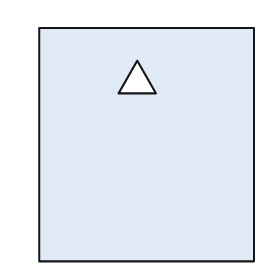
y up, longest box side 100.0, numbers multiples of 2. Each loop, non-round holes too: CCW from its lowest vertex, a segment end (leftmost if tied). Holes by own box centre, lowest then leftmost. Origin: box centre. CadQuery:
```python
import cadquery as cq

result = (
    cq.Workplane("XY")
    .moveTo(-46.0, -50.0)
    .lineTo(46.0, -50.0)
    .lineTo(46.0, 50.0)
    .lineTo(-46.0, 50.0)
    .close()
    .moveTo(-12.0, 22.0)
    .lineTo(4.0, 22.0)
    .lineTo(-4.0, 36.0)
    .close()
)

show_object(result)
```